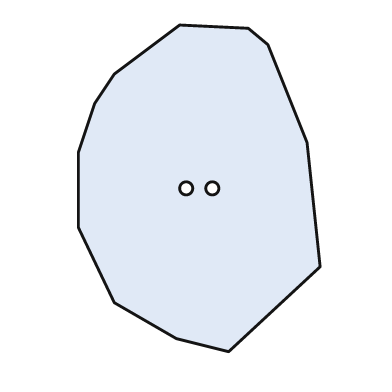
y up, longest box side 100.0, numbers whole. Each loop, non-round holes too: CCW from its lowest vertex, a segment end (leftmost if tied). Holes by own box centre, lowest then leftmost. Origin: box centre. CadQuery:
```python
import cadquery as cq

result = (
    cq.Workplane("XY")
    .moveTo(9.0, -50.0)
    .lineTo(37.0, -24.0)
    .lineTo(33.0, 14.0)
    .lineTo(21.0, 44.0)
    .lineTo(15.0, 49.0)
    .lineTo(-6.0, 50.0)
    .lineTo(-26.0, 35.0)
    .lineTo(-32.0, 26.0)
    .lineTo(-37.0, 11.0)
    .lineTo(-37.0, -12.0)
    .lineTo(-26.0, -35.0)
    .lineTo(-7.0, -46.0)
    .close()
    .moveTo(-4.0, 0.0)
    .circle(2.0)
    .moveTo(4.0, 0.0)
    .circle(2.0)
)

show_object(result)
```